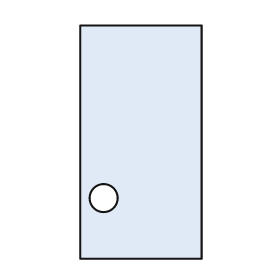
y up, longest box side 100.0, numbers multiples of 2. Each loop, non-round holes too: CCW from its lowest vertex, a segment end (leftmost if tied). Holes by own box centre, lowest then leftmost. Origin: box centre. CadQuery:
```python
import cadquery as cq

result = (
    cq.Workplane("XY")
    .moveTo(-26.0, -50.0)
    .lineTo(26.0, -50.0)
    .lineTo(26.0, 50.0)
    .lineTo(-26.0, 50.0)
    .close()
    .moveTo(-16.0, -24.0)
    .circle(6.0)
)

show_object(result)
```